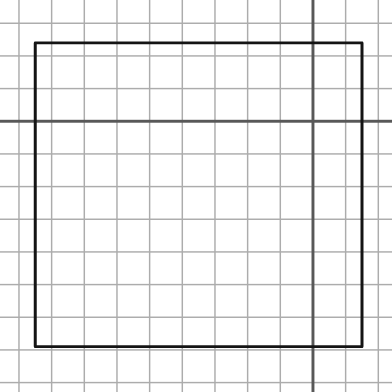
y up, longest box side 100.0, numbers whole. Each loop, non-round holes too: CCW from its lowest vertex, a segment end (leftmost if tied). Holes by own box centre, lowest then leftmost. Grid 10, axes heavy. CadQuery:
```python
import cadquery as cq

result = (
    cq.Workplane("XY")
    .moveTo(-85.0, -69.0)
    .lineTo(15.0, -69.0)
    .lineTo(15.0, 24.0)
    .lineTo(-85.0, 24.0)
    .close()
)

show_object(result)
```